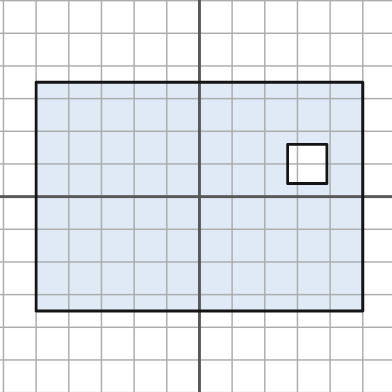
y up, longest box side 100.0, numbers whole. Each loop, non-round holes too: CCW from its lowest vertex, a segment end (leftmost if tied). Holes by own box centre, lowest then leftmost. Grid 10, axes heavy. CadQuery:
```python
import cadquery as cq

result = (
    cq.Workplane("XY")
    .moveTo(-50.0, -35.0)
    .lineTo(50.0, -35.0)
    .lineTo(50.0, 35.0)
    .lineTo(-50.0, 35.0)
    .close()
    .moveTo(27.0, 4.0)
    .lineTo(39.0, 4.0)
    .lineTo(39.0, 16.0)
    .lineTo(27.0, 16.0)
    .close()
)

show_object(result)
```